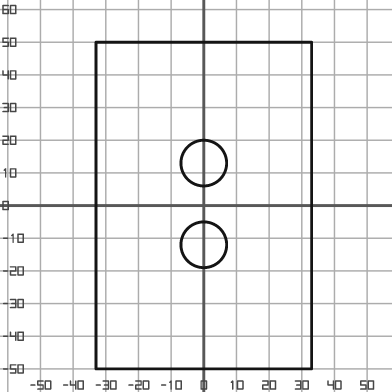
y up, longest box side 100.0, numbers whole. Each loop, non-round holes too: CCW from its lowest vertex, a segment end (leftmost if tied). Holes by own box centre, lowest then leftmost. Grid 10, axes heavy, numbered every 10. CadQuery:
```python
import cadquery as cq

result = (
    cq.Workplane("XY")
    .moveTo(-33.0, -50.0)
    .lineTo(33.0, -50.0)
    .lineTo(33.0, 50.0)
    .lineTo(-33.0, 50.0)
    .close()
    .moveTo(0.0, -12.0)
    .circle(7.0)
    .moveTo(0.0, 13.0)
    .circle(7.0)
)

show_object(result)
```